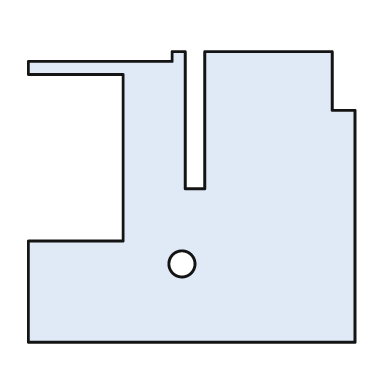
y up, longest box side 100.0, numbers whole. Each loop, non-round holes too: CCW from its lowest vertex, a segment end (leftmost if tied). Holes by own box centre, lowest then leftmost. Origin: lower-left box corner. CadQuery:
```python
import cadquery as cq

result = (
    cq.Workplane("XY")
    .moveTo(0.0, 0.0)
    .lineTo(100.0, 0.0)
    .lineTo(100.0, 71.0)
    .lineTo(93.0, 71.0)
    .lineTo(93.0, 89.0)
    .lineTo(54.0, 89.0)
    .lineTo(54.0, 47.0)
    .lineTo(48.0, 47.0)
    .lineTo(48.0, 89.0)
    .lineTo(44.0, 89.0)
    .lineTo(44.0, 86.0)
    .lineTo(0.0, 86.0)
    .lineTo(0.0, 82.0)
    .lineTo(29.0, 82.0)
    .lineTo(29.0, 31.0)
    .lineTo(0.0, 31.0)
    .close()
    .moveTo(47.0, 24.0)
    .circle(4.0)
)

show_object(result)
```